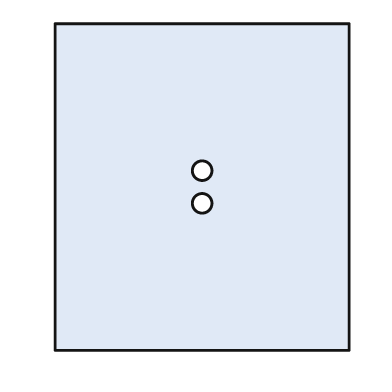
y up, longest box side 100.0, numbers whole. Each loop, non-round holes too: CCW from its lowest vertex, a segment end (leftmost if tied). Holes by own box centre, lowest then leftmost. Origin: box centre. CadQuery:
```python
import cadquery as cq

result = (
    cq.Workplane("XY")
    .moveTo(-45.0, -50.0)
    .lineTo(45.0, -50.0)
    .lineTo(45.0, 50.0)
    .lineTo(-45.0, 50.0)
    .close()
    .moveTo(0.0, -5.0)
    .circle(3.0)
    .moveTo(0.0, 5.0)
    .circle(3.0)
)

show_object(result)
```